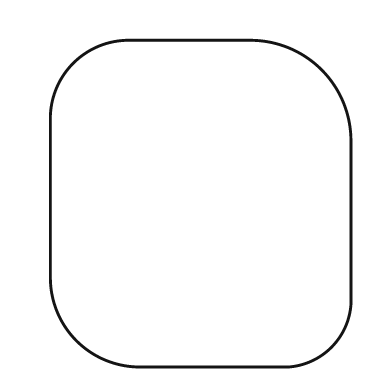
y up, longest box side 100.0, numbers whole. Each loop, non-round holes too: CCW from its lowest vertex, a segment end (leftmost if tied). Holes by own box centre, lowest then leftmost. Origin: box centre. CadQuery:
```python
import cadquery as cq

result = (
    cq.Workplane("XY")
    .moveTo(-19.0, -50.0)
    .lineTo(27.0, -50.0)
    .threePointArc((40.0, -44.0), (46.0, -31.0))
    .lineTo(46.0, 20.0)
    .threePointArc((37.0, 41.0), (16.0, 50.0))
    .lineTo(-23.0, 50.0)
    .threePointArc((-39.0, 43.0), (-46.0, 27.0))
    .lineTo(-46.0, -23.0)
    .threePointArc((-38.0, -42.0), (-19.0, -50.0))
    .close()
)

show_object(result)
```